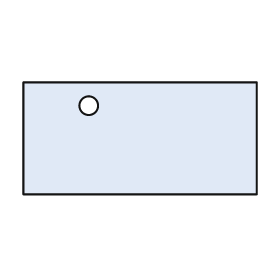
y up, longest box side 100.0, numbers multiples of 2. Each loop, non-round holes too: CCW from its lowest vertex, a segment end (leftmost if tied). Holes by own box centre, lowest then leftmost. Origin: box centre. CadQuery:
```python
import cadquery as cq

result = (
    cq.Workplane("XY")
    .moveTo(-50.0, -24.0)
    .lineTo(50.0, -24.0)
    .lineTo(50.0, 24.0)
    .lineTo(-50.0, 24.0)
    .close()
    .moveTo(-22.0, 14.0)
    .circle(4.0)
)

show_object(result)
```